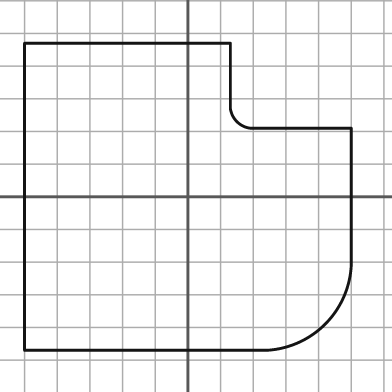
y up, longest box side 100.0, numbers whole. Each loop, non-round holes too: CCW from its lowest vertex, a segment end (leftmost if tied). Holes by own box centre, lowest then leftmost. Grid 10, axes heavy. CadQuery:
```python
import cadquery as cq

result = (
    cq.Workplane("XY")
    .moveTo(-50.0, -47.0)
    .lineTo(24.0, -47.0)
    .threePointArc((42.0, -39.0), (50.0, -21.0))
    .lineTo(50.0, 21.0)
    .lineTo(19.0, 21.0)
    .threePointArc((15.0, 23.0), (13.0, 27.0))
    .lineTo(13.0, 47.0)
    .lineTo(-50.0, 47.0)
    .close()
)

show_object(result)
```